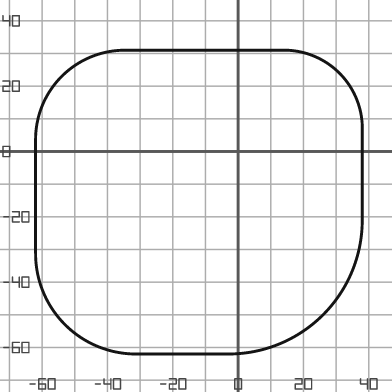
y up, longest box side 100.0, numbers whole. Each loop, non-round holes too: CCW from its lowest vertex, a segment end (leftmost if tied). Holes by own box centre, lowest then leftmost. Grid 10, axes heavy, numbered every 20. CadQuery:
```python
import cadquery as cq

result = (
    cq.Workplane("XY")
    .moveTo(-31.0, -62.0)
    .lineTo(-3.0, -62.0)
    .threePointArc((26.0, -50.0), (38.0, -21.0))
    .lineTo(38.0, 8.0)
    .threePointArc((31.0, 24.0), (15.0, 31.0))
    .lineTo(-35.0, 31.0)
    .threePointArc((-54.0, 23.0), (-62.0, 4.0))
    .lineTo(-62.0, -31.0)
    .threePointArc((-53.0, -53.0), (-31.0, -62.0))
    .close()
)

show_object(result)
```